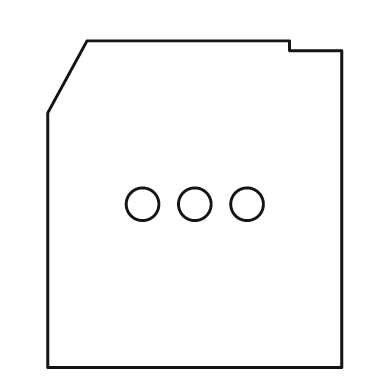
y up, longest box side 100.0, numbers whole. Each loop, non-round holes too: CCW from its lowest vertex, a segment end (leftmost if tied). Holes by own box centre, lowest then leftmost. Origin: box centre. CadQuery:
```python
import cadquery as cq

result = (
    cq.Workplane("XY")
    .moveTo(-45.0, -50.0)
    .lineTo(45.0, -50.0)
    .lineTo(45.0, 47.0)
    .lineTo(29.0, 47.0)
    .lineTo(29.0, 50.0)
    .lineTo(-33.0, 50.0)
    .lineTo(-45.0, 28.0)
    .close()
    .moveTo(-16.0, 0.0)
    .circle(5.0)
    .moveTo(0.0, 0.0)
    .circle(5.0)
    .moveTo(16.0, 0.0)
    .circle(5.0)
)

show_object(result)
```